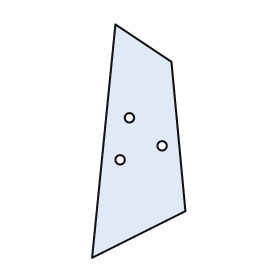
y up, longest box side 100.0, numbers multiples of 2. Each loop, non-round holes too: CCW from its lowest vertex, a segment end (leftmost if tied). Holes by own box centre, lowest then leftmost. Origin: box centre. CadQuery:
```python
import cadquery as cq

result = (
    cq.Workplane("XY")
    .moveTo(-20.0, -50.0)
    .lineTo(20.0, -30.0)
    .lineTo(14.0, 34.0)
    .lineTo(-10.0, 50.0)
    .close()
    .moveTo(-8.0, -8.0)
    .circle(2.0)
    .moveTo(10.0, -2.0)
    .circle(2.0)
    .moveTo(-4.0, 10.0)
    .circle(2.0)
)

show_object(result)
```